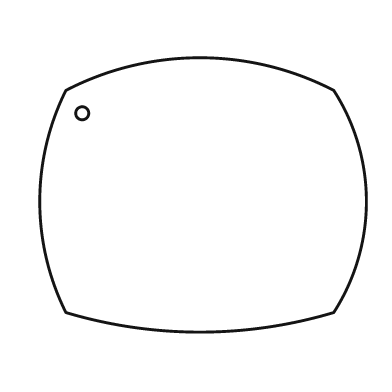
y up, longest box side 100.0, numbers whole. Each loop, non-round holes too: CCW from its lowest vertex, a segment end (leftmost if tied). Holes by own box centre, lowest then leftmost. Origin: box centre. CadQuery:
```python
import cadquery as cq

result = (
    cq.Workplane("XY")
    .moveTo(-42.0, -36.0)
    .threePointArc((-1.0, -42.0), (40.0, -36.0))
    .threePointArc((50.0, -2.0), (40.0, 32.0))
    .threePointArc((-1.0, 42.0), (-42.0, 32.0))
    .threePointArc((-50.0, -2.0), (-42.0, -36.0))
    .close()
    .moveTo(-37.0, 25.0)
    .circle(2.0)
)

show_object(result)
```